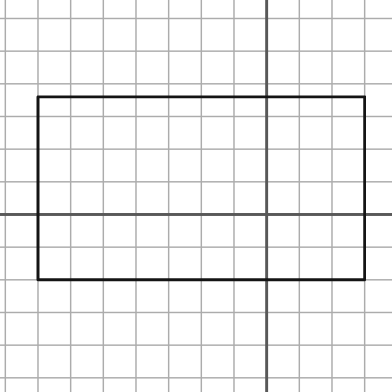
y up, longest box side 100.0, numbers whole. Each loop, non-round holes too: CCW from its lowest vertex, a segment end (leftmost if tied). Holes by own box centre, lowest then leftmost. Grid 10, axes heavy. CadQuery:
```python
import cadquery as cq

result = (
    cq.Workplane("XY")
    .moveTo(-70.0, -20.0)
    .lineTo(30.0, -20.0)
    .lineTo(30.0, 36.0)
    .lineTo(-70.0, 36.0)
    .close()
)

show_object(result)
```